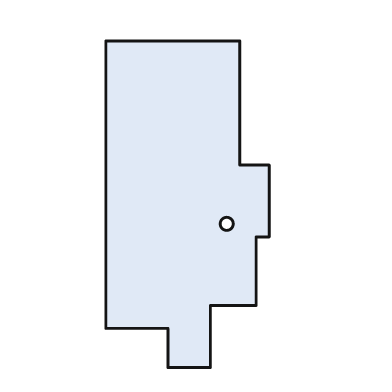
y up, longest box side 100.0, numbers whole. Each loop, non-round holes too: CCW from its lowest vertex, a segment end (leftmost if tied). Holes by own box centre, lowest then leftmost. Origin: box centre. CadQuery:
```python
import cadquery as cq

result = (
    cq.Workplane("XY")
    .moveTo(-6.0, -50.0)
    .lineTo(7.0, -50.0)
    .lineTo(7.0, -31.0)
    .lineTo(21.0, -31.0)
    .lineTo(21.0, -10.0)
    .lineTo(25.0, -10.0)
    .lineTo(25.0, 12.0)
    .lineTo(16.0, 12.0)
    .lineTo(16.0, 50.0)
    .lineTo(-25.0, 50.0)
    .lineTo(-25.0, -38.0)
    .lineTo(-6.0, -38.0)
    .close()
    .moveTo(12.0, -6.0)
    .circle(2.0)
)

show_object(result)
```